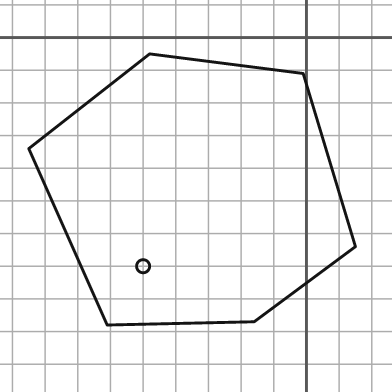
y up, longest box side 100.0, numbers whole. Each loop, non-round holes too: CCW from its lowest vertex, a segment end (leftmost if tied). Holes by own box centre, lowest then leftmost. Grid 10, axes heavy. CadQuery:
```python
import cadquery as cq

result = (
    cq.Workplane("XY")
    .moveTo(-61.0, -88.0)
    .lineTo(-16.0, -87.0)
    .lineTo(15.0, -64.0)
    .lineTo(-1.0, -11.0)
    .lineTo(-48.0, -5.0)
    .lineTo(-85.0, -34.0)
    .close()
    .moveTo(-50.0, -70.0)
    .circle(2.0)
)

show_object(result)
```